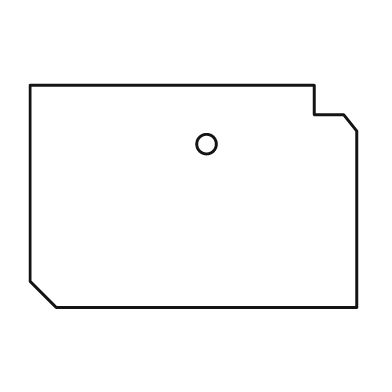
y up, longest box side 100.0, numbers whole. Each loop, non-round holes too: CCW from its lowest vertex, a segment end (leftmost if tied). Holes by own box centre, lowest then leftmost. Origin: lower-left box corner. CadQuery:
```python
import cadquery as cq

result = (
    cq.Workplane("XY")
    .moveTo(8.0, 0.0)
    .lineTo(100.0, 0.0)
    .lineTo(100.0, 54.0)
    .lineTo(96.0, 59.0)
    .lineTo(87.0, 59.0)
    .lineTo(87.0, 68.0)
    .lineTo(0.0, 68.0)
    .lineTo(0.0, 8.0)
    .close()
    .moveTo(54.0, 50.0)
    .circle(3.0)
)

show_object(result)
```